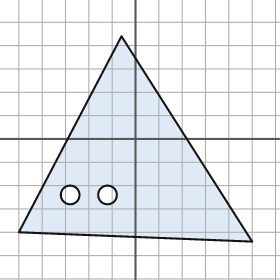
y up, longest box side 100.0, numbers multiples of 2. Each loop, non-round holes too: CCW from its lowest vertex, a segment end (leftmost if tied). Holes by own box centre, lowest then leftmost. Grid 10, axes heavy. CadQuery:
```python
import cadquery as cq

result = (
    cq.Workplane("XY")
    .moveTo(50.0, -44.0)
    .lineTo(-6.0, 44.0)
    .lineTo(-50.0, -40.0)
    .close()
    .moveTo(-28.0, -24.0)
    .circle(4.0)
    .moveTo(-12.0, -24.0)
    .circle(4.0)
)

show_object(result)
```